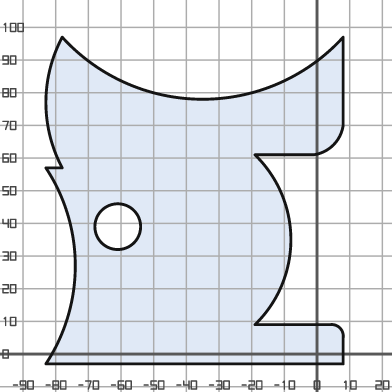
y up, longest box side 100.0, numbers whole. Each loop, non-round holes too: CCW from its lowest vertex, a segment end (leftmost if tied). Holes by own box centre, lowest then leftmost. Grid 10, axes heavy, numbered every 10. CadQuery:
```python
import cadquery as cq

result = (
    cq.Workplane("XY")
    .moveTo(-83.0, -3.0)
    .lineTo(8.0, -3.0)
    .lineTo(8.0, 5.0)
    .threePointArc((7.0, 8.0), (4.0, 9.0))
    .lineTo(-19.0, 9.0)
    .threePointArc((-8.0, 35.0), (-19.0, 61.0))
    .lineTo(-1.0, 61.0)
    .threePointArc((5.0, 64.0), (8.0, 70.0))
    .lineTo(8.0, 97.0)
    .threePointArc((-35.0, 78.0), (-78.0, 97.0))
    .threePointArc((-83.0, 77.0), (-78.0, 57.0))
    .lineTo(-83.0, 57.0)
    .threePointArc((-74.0, 27.0), (-83.0, -3.0))
    .close()
    .moveTo(-61.0, 39.0)
    .circle(7.0)
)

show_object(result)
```